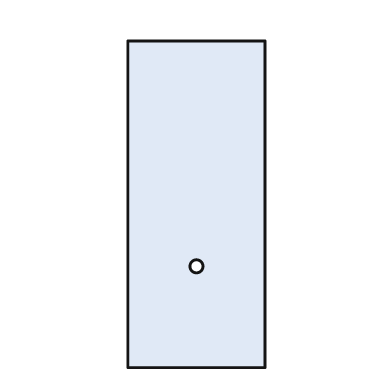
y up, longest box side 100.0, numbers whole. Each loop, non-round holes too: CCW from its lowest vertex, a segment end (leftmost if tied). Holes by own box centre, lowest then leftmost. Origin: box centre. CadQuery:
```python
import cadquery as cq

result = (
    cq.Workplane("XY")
    .moveTo(-21.0, -50.0)
    .lineTo(21.0, -50.0)
    .lineTo(21.0, 50.0)
    .lineTo(-21.0, 50.0)
    .close()
    .moveTo(0.0, -19.0)
    .circle(2.0)
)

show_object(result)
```